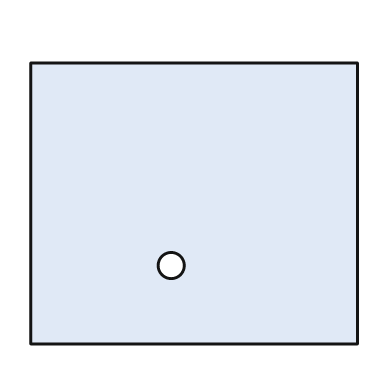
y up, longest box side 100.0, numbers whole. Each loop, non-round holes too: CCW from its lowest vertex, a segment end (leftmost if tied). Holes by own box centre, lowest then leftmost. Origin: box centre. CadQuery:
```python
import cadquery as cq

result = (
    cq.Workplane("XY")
    .moveTo(-50.0, -43.0)
    .lineTo(50.0, -43.0)
    .lineTo(50.0, 43.0)
    .lineTo(-50.0, 43.0)
    .close()
    .moveTo(-7.0, -19.0)
    .circle(4.0)
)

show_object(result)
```